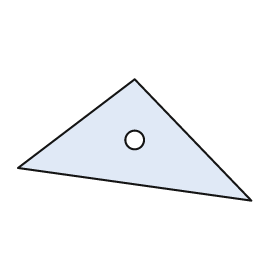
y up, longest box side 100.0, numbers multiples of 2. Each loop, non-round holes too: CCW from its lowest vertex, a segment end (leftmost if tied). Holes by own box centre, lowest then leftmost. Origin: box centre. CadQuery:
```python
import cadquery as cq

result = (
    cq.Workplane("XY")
    .moveTo(50.0, -26.0)
    .lineTo(0.0, 26.0)
    .lineTo(-50.0, -12.0)
    .close()
    .moveTo(0.0, 0.0)
    .circle(4.0)
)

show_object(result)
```